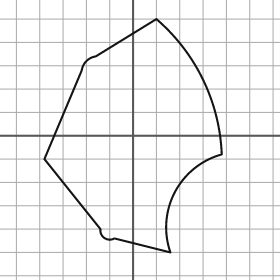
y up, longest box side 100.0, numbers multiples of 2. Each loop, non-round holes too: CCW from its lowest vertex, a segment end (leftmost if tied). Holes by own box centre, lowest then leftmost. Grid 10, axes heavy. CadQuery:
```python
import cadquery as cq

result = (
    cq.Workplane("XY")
    .moveTo(16.0, -50.0)
    .threePointArc((18.0, -24.0), (38.0, -8.0))
    .threePointArc((30.0, 24.0), (10.0, 50.0))
    .lineTo(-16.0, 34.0)
    .threePointArc((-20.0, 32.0), (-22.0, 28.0))
    .lineTo(-38.0, -10.0)
    .lineTo(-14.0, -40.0)
    .threePointArc((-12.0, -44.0), (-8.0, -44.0))
    .close()
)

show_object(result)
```